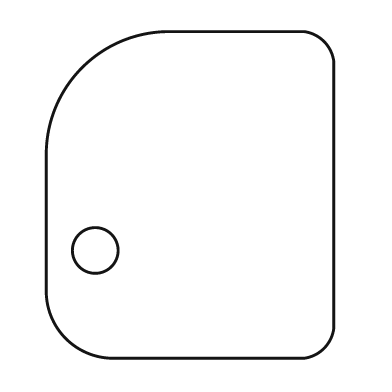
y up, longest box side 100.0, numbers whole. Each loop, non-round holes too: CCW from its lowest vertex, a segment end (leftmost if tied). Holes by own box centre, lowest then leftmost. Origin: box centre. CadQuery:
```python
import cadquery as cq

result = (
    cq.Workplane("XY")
    .moveTo(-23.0, -50.0)
    .lineTo(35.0, -50.0)
    .threePointArc((41.0, -47.0), (44.0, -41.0))
    .lineTo(44.0, 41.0)
    .threePointArc((41.0, 47.0), (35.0, 50.0))
    .lineTo(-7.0, 50.0)
    .threePointArc((-33.0, 39.0), (-44.0, 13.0))
    .lineTo(-44.0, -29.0)
    .threePointArc((-38.0, -44.0), (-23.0, -50.0))
    .close()
    .moveTo(-29.0, -17.0)
    .circle(7.0)
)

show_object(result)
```